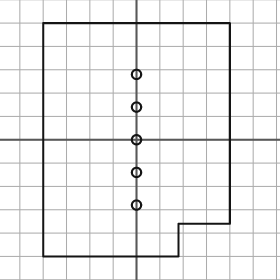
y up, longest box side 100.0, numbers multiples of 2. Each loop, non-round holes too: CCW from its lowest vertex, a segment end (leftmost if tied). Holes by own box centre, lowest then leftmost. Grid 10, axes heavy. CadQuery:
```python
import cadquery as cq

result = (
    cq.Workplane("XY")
    .moveTo(-40.0, -50.0)
    .lineTo(18.0, -50.0)
    .lineTo(18.0, -36.0)
    .lineTo(40.0, -36.0)
    .lineTo(40.0, 50.0)
    .lineTo(-40.0, 50.0)
    .close()
    .moveTo(0.0, -28.0)
    .circle(2.0)
    .moveTo(0.0, -14.0)
    .circle(2.0)
    .moveTo(0.0, 0.0)
    .circle(2.0)
    .moveTo(0.0, 14.0)
    .circle(2.0)
    .moveTo(0.0, 28.0)
    .circle(2.0)
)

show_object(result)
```